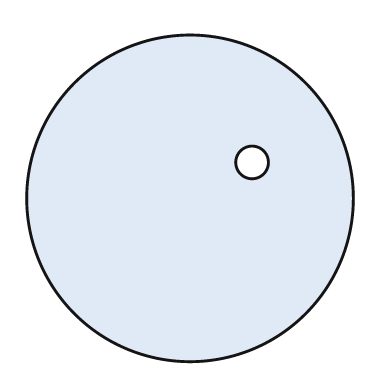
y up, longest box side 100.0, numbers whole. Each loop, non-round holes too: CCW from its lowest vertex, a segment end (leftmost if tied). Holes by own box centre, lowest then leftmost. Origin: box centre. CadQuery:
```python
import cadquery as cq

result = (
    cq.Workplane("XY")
    .moveTo(0.0, 0.0)
    .circle(50.0)
    .moveTo(19.0, 11.0)
    .circle(5.0)
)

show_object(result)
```